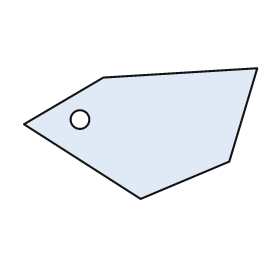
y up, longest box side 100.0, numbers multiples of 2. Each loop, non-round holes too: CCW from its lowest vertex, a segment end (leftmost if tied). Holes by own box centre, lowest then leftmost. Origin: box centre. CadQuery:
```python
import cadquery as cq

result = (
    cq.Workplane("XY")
    .moveTo(0.0, -28.0)
    .lineTo(38.0, -12.0)
    .lineTo(50.0, 28.0)
    .lineTo(-16.0, 24.0)
    .lineTo(-50.0, 4.0)
    .close()
    .moveTo(-26.0, 6.0)
    .circle(4.0)
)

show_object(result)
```